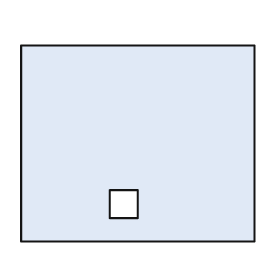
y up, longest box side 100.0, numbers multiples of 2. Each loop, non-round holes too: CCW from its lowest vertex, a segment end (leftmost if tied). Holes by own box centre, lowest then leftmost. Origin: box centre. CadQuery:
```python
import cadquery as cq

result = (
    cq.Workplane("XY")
    .moveTo(-50.0, -42.0)
    .lineTo(50.0, -42.0)
    .lineTo(50.0, 42.0)
    .lineTo(-50.0, 42.0)
    .close()
    .moveTo(-12.0, -32.0)
    .lineTo(0.0, -32.0)
    .lineTo(0.0, -20.0)
    .lineTo(-12.0, -20.0)
    .close()
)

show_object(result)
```